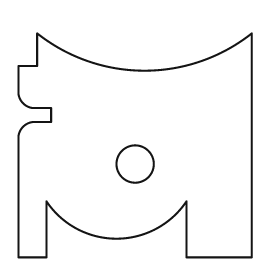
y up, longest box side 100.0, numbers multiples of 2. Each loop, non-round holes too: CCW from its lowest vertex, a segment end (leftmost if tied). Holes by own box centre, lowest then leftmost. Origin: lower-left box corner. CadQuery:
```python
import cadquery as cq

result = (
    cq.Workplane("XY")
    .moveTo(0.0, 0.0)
    .lineTo(12.0, 0.0)
    .lineTo(12.0, 24.0)
    .threePointArc((42.0, 8.0), (72.0, 24.0))
    .lineTo(72.0, 0.0)
    .lineTo(100.0, 0.0)
    .lineTo(100.0, 96.0)
    .threePointArc((54.0, 80.0), (8.0, 96.0))
    .lineTo(8.0, 82.0)
    .lineTo(0.0, 82.0)
    .lineTo(0.0, 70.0)
    .threePointArc((2.0, 66.0), (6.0, 64.0))
    .lineTo(14.0, 64.0)
    .lineTo(14.0, 58.0)
    .lineTo(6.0, 58.0)
    .threePointArc((2.0, 56.0), (0.0, 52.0))
    .close()
    .moveTo(50.0, 40.0)
    .circle(8.0)
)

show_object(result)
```